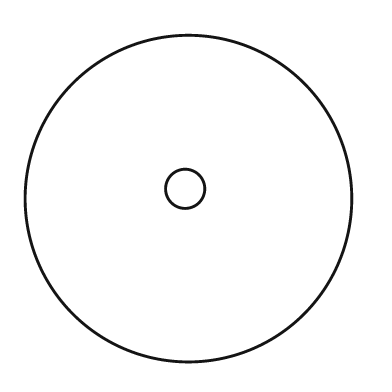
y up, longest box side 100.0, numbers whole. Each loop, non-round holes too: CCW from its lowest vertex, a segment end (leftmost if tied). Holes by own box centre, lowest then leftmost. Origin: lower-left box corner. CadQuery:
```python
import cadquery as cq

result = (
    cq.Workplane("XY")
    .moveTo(50.0, 50.0)
    .circle(50.0)
    .moveTo(49.0, 53.0)
    .circle(6.0)
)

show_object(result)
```